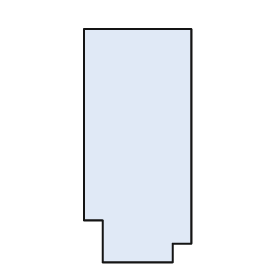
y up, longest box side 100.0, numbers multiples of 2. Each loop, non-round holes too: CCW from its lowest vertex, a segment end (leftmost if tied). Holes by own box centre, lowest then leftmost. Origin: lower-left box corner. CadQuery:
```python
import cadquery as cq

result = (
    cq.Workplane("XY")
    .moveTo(8.0, 0.0)
    .lineTo(38.0, 0.0)
    .lineTo(38.0, 8.0)
    .lineTo(46.0, 8.0)
    .lineTo(46.0, 100.0)
    .lineTo(0.0, 100.0)
    .lineTo(0.0, 18.0)
    .lineTo(8.0, 18.0)
    .close()
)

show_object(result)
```